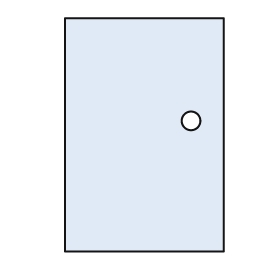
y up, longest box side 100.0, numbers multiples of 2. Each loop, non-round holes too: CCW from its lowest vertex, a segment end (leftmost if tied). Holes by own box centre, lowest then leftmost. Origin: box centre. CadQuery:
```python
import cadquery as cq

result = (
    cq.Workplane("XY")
    .moveTo(-34.0, -50.0)
    .lineTo(34.0, -50.0)
    .lineTo(34.0, 50.0)
    .lineTo(-34.0, 50.0)
    .close()
    .moveTo(20.0, 6.0)
    .circle(4.0)
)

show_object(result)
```